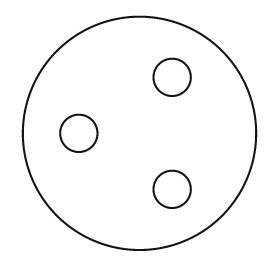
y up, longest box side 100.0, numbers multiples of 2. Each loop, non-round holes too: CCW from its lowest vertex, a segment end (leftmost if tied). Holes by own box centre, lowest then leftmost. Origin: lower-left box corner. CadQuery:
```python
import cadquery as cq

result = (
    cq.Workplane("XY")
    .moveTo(50.0, 50.0)
    .circle(50.0)
    .moveTo(64.0, 26.0)
    .circle(8.0)
    .moveTo(24.0, 50.0)
    .circle(8.0)
    .moveTo(64.0, 74.0)
    .circle(8.0)
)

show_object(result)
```